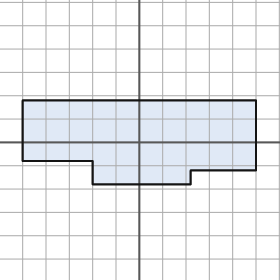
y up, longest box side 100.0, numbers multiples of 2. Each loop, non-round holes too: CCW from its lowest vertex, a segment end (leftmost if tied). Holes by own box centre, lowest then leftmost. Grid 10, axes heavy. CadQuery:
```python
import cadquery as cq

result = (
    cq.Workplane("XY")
    .moveTo(-20.0, -18.0)
    .lineTo(22.0, -18.0)
    .lineTo(22.0, -12.0)
    .lineTo(50.0, -12.0)
    .lineTo(50.0, 18.0)
    .lineTo(-50.0, 18.0)
    .lineTo(-50.0, -8.0)
    .lineTo(-20.0, -8.0)
    .close()
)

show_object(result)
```